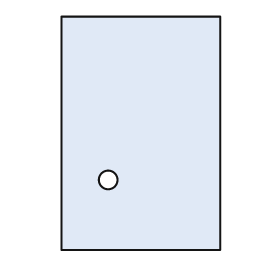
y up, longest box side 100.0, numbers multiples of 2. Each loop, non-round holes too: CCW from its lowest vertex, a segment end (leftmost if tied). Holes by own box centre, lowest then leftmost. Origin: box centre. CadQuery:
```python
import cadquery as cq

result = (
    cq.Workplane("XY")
    .moveTo(-34.0, -50.0)
    .lineTo(34.0, -50.0)
    .lineTo(34.0, 50.0)
    .lineTo(-34.0, 50.0)
    .close()
    .moveTo(-14.0, -20.0)
    .circle(4.0)
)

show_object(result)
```